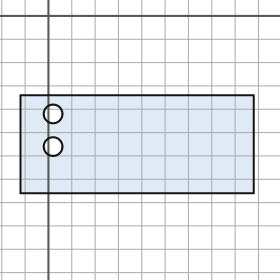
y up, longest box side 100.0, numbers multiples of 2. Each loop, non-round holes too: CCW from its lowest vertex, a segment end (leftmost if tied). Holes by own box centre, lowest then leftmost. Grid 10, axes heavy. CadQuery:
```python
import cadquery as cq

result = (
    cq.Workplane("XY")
    .moveTo(-12.0, -76.0)
    .lineTo(88.0, -76.0)
    .lineTo(88.0, -34.0)
    .lineTo(-12.0, -34.0)
    .close()
    .moveTo(2.0, -56.0)
    .circle(4.0)
    .moveTo(2.0, -42.0)
    .circle(4.0)
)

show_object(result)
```